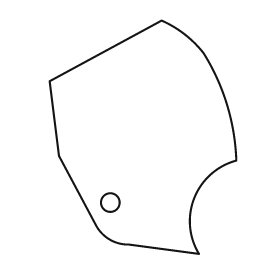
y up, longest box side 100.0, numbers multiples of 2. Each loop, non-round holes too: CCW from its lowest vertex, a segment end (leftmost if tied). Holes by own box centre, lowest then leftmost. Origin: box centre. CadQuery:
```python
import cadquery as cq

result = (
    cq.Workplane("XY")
    .moveTo(24.0, -50.0)
    .threePointArc((22.0, -26.0), (40.0, -10.0))
    .threePointArc((36.0, 14.0), (26.0, 36.0))
    .threePointArc((18.0, 44.0), (8.0, 50.0))
    .lineTo(-40.0, 24.0)
    .lineTo(-36.0, -8.0)
    .lineTo(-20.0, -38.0)
    .threePointArc((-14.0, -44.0), (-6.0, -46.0))
    .close()
    .moveTo(-14.0, -28.0)
    .circle(4.0)
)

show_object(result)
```